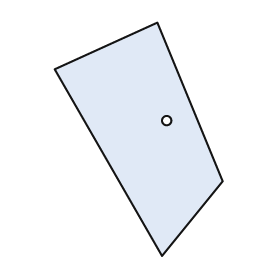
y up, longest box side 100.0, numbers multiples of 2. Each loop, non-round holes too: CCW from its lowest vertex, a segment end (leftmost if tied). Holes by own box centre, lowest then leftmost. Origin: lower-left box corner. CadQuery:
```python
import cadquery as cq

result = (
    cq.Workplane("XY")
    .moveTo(46.0, 0.0)
    .lineTo(72.0, 32.0)
    .lineTo(44.0, 100.0)
    .lineTo(0.0, 80.0)
    .close()
    .moveTo(48.0, 58.0)
    .circle(2.0)
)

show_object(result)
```